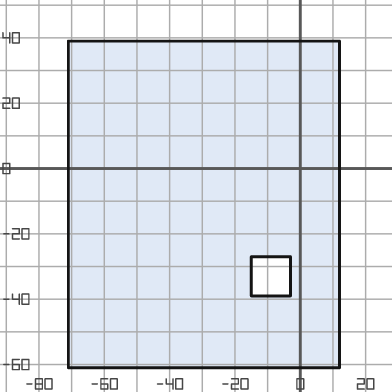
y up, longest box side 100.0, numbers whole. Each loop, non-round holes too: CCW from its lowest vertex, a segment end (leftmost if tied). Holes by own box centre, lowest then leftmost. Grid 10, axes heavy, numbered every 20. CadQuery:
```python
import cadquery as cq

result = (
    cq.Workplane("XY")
    .moveTo(-71.0, -61.0)
    .lineTo(12.0, -61.0)
    .lineTo(12.0, 39.0)
    .lineTo(-71.0, 39.0)
    .close()
    .moveTo(-15.0, -39.0)
    .lineTo(-3.0, -39.0)
    .lineTo(-3.0, -27.0)
    .lineTo(-15.0, -27.0)
    .close()
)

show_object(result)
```